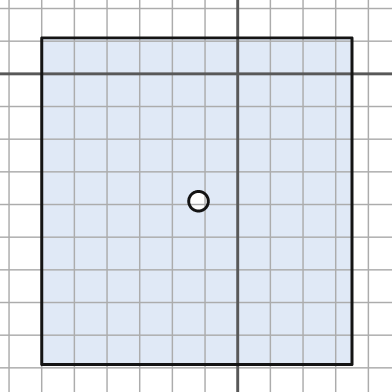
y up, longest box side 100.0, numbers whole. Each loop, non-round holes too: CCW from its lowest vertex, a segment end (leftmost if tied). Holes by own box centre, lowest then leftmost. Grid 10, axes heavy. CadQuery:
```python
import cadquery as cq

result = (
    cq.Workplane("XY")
    .moveTo(-60.0, -89.0)
    .lineTo(35.0, -89.0)
    .lineTo(35.0, 11.0)
    .lineTo(-60.0, 11.0)
    .close()
    .moveTo(-12.0, -39.0)
    .circle(3.0)
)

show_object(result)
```